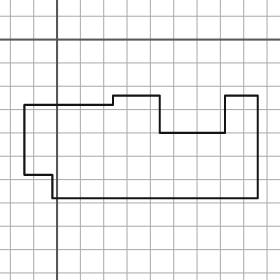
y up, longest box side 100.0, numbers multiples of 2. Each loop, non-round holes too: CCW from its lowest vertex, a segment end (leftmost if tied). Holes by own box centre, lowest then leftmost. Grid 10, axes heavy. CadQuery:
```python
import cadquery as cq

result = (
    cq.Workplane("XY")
    .moveTo(-2.0, -68.0)
    .lineTo(86.0, -68.0)
    .lineTo(86.0, -24.0)
    .lineTo(72.0, -24.0)
    .lineTo(72.0, -40.0)
    .lineTo(44.0, -40.0)
    .lineTo(44.0, -24.0)
    .lineTo(24.0, -24.0)
    .lineTo(24.0, -28.0)
    .lineTo(-14.0, -28.0)
    .lineTo(-14.0, -58.0)
    .lineTo(-2.0, -58.0)
    .close()
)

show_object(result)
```